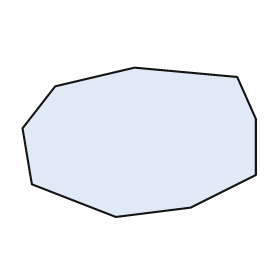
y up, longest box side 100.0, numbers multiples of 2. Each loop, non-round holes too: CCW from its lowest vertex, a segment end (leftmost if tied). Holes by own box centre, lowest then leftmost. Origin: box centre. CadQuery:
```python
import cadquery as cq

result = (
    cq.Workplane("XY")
    .moveTo(-10.0, -32.0)
    .lineTo(22.0, -28.0)
    .lineTo(50.0, -14.0)
    .lineTo(50.0, 10.0)
    .lineTo(42.0, 28.0)
    .lineTo(-2.0, 32.0)
    .lineTo(-36.0, 24.0)
    .lineTo(-50.0, 6.0)
    .lineTo(-46.0, -18.0)
    .close()
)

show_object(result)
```